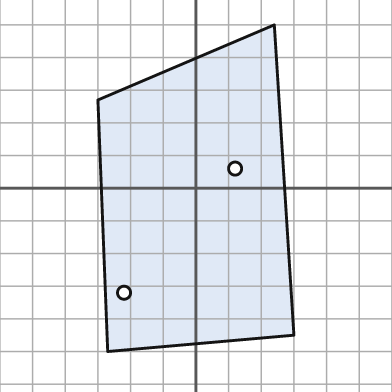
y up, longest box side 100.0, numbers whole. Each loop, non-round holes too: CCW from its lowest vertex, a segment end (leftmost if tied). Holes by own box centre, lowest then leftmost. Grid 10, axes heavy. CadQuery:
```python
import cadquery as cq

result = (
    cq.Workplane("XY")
    .moveTo(-27.0, -50.0)
    .lineTo(30.0, -45.0)
    .lineTo(24.0, 50.0)
    .lineTo(-30.0, 27.0)
    .close()
    .moveTo(-22.0, -32.0)
    .circle(2.0)
    .moveTo(12.0, 6.0)
    .circle(2.0)
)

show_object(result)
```